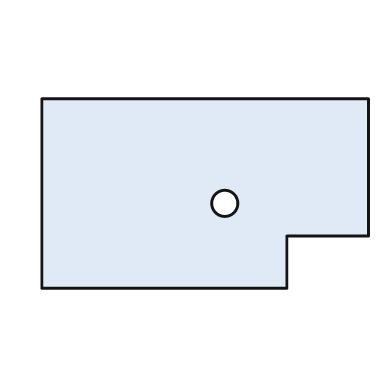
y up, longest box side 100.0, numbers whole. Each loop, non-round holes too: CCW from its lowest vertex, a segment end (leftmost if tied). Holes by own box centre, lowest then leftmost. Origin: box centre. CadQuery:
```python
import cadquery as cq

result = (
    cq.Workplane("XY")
    .moveTo(-50.0, -29.0)
    .lineTo(25.0, -29.0)
    .lineTo(25.0, -13.0)
    .lineTo(50.0, -13.0)
    .lineTo(50.0, 29.0)
    .lineTo(-50.0, 29.0)
    .close()
    .moveTo(6.0, -3.0)
    .circle(4.0)
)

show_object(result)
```